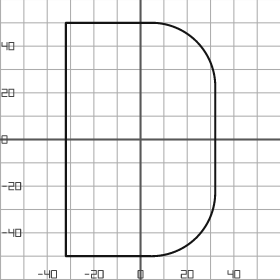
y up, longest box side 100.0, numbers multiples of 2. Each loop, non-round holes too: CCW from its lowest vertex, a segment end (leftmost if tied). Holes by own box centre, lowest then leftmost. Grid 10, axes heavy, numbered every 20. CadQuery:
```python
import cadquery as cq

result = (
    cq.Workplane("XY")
    .moveTo(-32.0, -50.0)
    .lineTo(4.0, -50.0)
    .threePointArc((24.0, -42.0), (32.0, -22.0))
    .lineTo(32.0, 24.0)
    .threePointArc((24.0, 42.0), (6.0, 50.0))
    .lineTo(-32.0, 50.0)
    .close()
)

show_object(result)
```